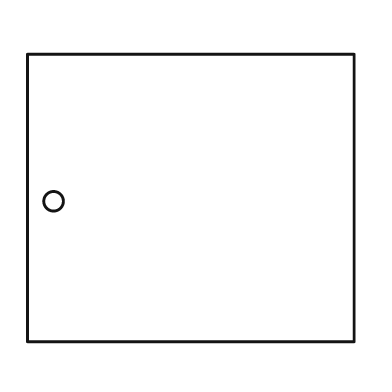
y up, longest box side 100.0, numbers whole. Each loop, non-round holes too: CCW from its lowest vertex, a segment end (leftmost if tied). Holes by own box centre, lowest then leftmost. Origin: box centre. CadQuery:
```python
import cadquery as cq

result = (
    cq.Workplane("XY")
    .moveTo(-50.0, -44.0)
    .lineTo(50.0, -44.0)
    .lineTo(50.0, 44.0)
    .lineTo(-50.0, 44.0)
    .close()
    .moveTo(-42.0, -1.0)
    .circle(3.0)
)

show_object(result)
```